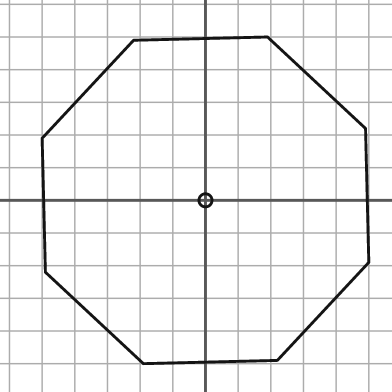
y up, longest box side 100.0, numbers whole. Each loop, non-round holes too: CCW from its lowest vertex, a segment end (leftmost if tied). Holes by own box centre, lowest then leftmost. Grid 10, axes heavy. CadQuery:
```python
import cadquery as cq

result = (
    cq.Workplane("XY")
    .moveTo(-19.0, -50.0)
    .lineTo(22.0, -49.0)
    .lineTo(50.0, -19.0)
    .lineTo(49.0, 22.0)
    .lineTo(19.0, 50.0)
    .lineTo(-22.0, 49.0)
    .lineTo(-50.0, 19.0)
    .lineTo(-49.0, -22.0)
    .close()
    .moveTo(0.0, 0.0)
    .circle(2.0)
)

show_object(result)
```